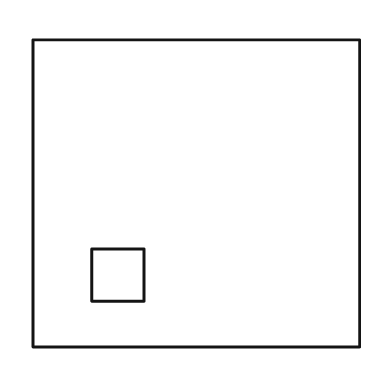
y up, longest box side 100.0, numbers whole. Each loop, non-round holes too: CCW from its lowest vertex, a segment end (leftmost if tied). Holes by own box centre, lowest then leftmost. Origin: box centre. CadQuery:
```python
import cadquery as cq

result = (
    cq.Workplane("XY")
    .moveTo(-50.0, -47.0)
    .lineTo(50.0, -47.0)
    .lineTo(50.0, 47.0)
    .lineTo(-50.0, 47.0)
    .close()
    .moveTo(-32.0, -33.0)
    .lineTo(-16.0, -33.0)
    .lineTo(-16.0, -17.0)
    .lineTo(-32.0, -17.0)
    .close()
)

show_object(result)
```